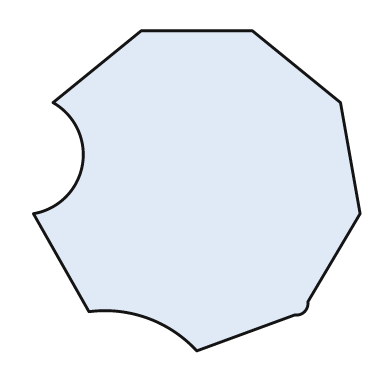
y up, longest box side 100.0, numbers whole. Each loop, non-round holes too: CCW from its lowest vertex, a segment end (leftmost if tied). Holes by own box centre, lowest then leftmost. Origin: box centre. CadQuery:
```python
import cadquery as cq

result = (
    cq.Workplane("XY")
    .moveTo(0.0, -49.0)
    .lineTo(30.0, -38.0)
    .threePointArc((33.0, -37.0), (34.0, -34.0))
    .lineTo(50.0, -7.0)
    .lineTo(44.0, 27.0)
    .lineTo(17.0, 49.0)
    .lineTo(-17.0, 49.0)
    .lineTo(-44.0, 27.0)
    .threePointArc((-35.0, 8.0), (-50.0, -7.0))
    .lineTo(-33.0, -37.0)
    .threePointArc((-15.0, -39.0), (0.0, -49.0))
    .close()
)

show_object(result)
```